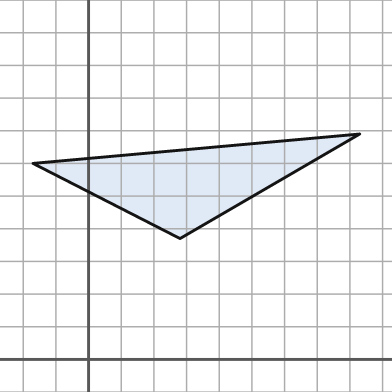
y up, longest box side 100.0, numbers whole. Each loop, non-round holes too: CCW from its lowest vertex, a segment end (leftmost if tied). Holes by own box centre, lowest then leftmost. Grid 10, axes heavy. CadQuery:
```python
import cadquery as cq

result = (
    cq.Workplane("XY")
    .moveTo(28.0, 37.0)
    .lineTo(83.0, 69.0)
    .lineTo(-17.0, 60.0)
    .close()
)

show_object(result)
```